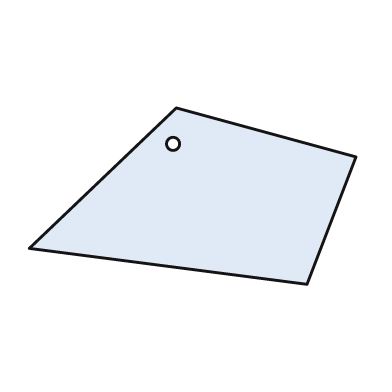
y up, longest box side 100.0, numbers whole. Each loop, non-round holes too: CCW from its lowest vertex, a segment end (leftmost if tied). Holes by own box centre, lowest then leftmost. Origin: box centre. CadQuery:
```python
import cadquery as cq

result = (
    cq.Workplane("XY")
    .moveTo(35.0, -27.0)
    .lineTo(50.0, 12.0)
    .lineTo(-5.0, 27.0)
    .lineTo(-50.0, -16.0)
    .close()
    .moveTo(-6.0, 16.0)
    .circle(2.0)
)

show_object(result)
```